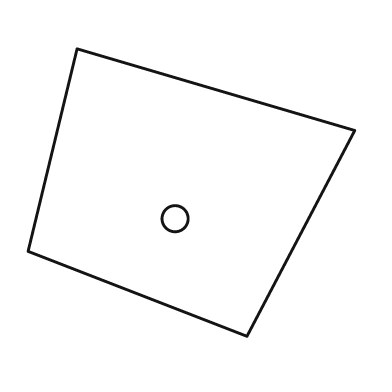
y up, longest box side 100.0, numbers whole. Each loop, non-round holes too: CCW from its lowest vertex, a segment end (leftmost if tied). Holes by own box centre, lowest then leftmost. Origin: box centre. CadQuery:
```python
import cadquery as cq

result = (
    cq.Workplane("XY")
    .moveTo(17.0, -44.0)
    .lineTo(50.0, 19.0)
    .lineTo(-35.0, 44.0)
    .lineTo(-50.0, -18.0)
    .close()
    .moveTo(-5.0, -8.0)
    .circle(4.0)
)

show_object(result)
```